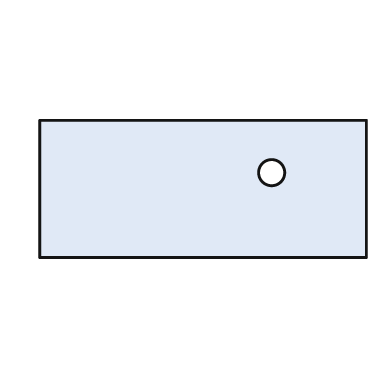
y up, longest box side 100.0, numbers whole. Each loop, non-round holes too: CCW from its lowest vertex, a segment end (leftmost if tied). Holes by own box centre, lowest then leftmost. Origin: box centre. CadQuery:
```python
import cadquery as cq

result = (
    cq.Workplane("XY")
    .moveTo(-50.0, -21.0)
    .lineTo(50.0, -21.0)
    .lineTo(50.0, 21.0)
    .lineTo(-50.0, 21.0)
    .close()
    .moveTo(21.0, 5.0)
    .circle(4.0)
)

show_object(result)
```